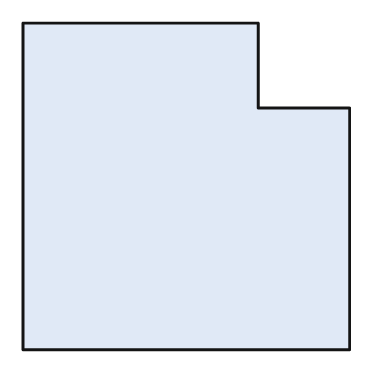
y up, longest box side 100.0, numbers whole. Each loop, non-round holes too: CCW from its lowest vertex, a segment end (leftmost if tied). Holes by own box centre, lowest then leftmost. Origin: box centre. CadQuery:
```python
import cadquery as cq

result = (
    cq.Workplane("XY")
    .moveTo(-50.0, -50.0)
    .lineTo(50.0, -50.0)
    .lineTo(50.0, 24.0)
    .lineTo(22.0, 24.0)
    .lineTo(22.0, 50.0)
    .lineTo(-50.0, 50.0)
    .close()
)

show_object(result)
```